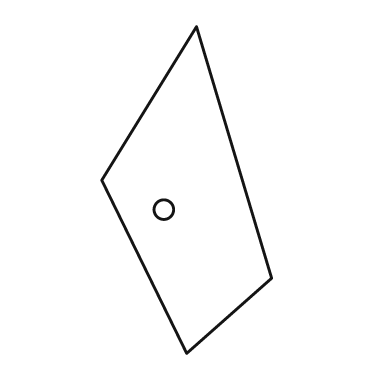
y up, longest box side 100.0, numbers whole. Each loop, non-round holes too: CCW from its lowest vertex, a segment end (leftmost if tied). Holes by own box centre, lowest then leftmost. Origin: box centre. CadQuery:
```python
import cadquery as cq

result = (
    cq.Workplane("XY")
    .moveTo(0.0, -50.0)
    .lineTo(26.0, -27.0)
    .lineTo(3.0, 50.0)
    .lineTo(-26.0, 3.0)
    .close()
    .moveTo(-7.0, -6.0)
    .circle(3.0)
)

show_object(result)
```